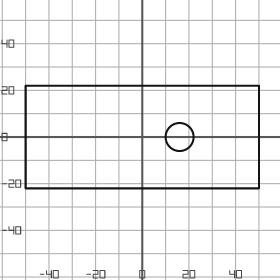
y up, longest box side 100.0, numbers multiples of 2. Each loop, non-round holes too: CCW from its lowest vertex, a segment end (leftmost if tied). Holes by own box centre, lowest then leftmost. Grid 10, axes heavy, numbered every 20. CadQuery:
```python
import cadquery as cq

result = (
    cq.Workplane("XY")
    .moveTo(-50.0, -22.0)
    .lineTo(50.0, -22.0)
    .lineTo(50.0, 22.0)
    .lineTo(-50.0, 22.0)
    .close()
    .moveTo(16.0, 0.0)
    .circle(6.0)
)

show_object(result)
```